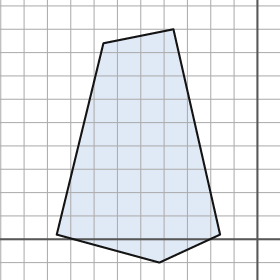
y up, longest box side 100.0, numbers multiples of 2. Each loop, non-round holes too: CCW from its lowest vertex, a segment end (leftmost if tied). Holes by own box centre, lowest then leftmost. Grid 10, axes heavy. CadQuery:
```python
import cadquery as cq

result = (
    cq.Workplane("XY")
    .moveTo(-42.0, -10.0)
    .lineTo(-16.0, 2.0)
    .lineTo(-36.0, 90.0)
    .lineTo(-66.0, 84.0)
    .lineTo(-86.0, 2.0)
    .close()
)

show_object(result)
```